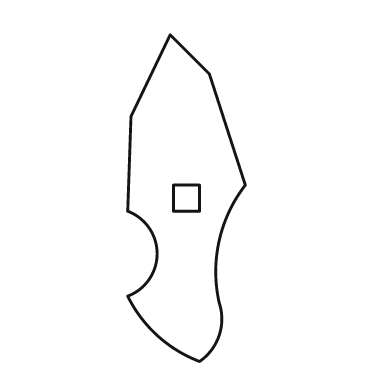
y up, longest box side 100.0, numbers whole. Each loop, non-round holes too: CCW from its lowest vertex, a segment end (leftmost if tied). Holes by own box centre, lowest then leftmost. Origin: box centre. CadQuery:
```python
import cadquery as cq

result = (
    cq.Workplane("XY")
    .moveTo(4.0, -50.0)
    .threePointArc((10.0, -42.0), (10.0, -32.0))
    .threePointArc((10.0, -13.0), (18.0, 4.0))
    .lineTo(7.0, 38.0)
    .lineTo(-5.0, 50.0)
    .lineTo(-17.0, 25.0)
    .lineTo(-18.0, -4.0)
    .threePointArc((-9.0, -17.0), (-18.0, -30.0))
    .threePointArc((-9.0, -42.0), (4.0, -50.0))
    .close()
    .moveTo(-4.0, -4.0)
    .lineTo(4.0, -4.0)
    .lineTo(4.0, 4.0)
    .lineTo(-4.0, 4.0)
    .close()
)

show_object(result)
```